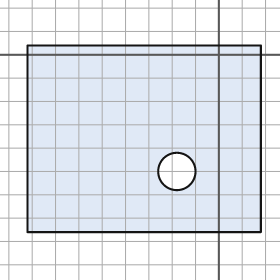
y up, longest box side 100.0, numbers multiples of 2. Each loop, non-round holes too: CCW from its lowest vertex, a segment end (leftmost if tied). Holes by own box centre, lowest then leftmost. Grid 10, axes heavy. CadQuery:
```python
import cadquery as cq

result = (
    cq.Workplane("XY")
    .moveTo(-82.0, -76.0)
    .lineTo(18.0, -76.0)
    .lineTo(18.0, 4.0)
    .lineTo(-82.0, 4.0)
    .close()
    .moveTo(-18.0, -50.0)
    .circle(8.0)
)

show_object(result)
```